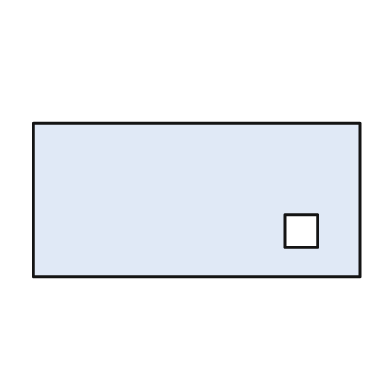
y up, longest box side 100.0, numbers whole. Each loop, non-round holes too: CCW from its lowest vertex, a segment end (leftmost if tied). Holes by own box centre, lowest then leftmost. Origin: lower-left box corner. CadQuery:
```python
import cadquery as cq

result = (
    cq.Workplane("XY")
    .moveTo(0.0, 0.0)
    .lineTo(100.0, 0.0)
    .lineTo(100.0, 47.0)
    .lineTo(0.0, 47.0)
    .close()
    .moveTo(77.0, 9.0)
    .lineTo(87.0, 9.0)
    .lineTo(87.0, 19.0)
    .lineTo(77.0, 19.0)
    .close()
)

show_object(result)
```